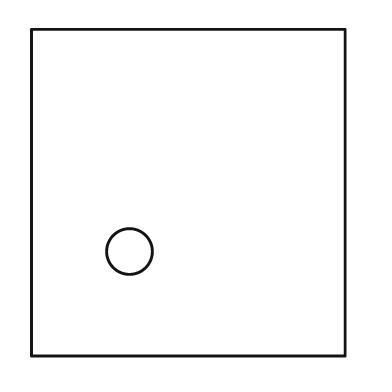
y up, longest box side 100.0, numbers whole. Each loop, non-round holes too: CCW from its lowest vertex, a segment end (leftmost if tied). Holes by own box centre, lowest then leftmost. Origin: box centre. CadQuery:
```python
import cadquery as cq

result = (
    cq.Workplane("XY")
    .moveTo(-48.0, -50.0)
    .lineTo(48.0, -50.0)
    .lineTo(48.0, 50.0)
    .lineTo(-48.0, 50.0)
    .close()
    .moveTo(-18.0, -18.0)
    .circle(7.0)
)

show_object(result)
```